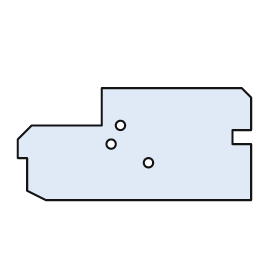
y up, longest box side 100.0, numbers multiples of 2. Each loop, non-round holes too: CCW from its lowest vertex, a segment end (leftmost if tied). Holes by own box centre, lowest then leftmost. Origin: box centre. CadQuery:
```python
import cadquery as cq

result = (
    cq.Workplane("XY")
    .moveTo(-38.0, -24.0)
    .lineTo(50.0, -24.0)
    .lineTo(50.0, 0.0)
    .lineTo(42.0, 0.0)
    .lineTo(42.0, 6.0)
    .lineTo(50.0, 6.0)
    .lineTo(50.0, 20.0)
    .lineTo(46.0, 24.0)
    .lineTo(-14.0, 24.0)
    .lineTo(-14.0, 8.0)
    .lineTo(-44.0, 8.0)
    .lineTo(-50.0, 2.0)
    .lineTo(-50.0, -6.0)
    .lineTo(-46.0, -6.0)
    .lineTo(-46.0, -20.0)
    .close()
    .moveTo(6.0, -8.0)
    .circle(2.0)
    .moveTo(-10.0, 0.0)
    .circle(2.0)
    .moveTo(-6.0, 8.0)
    .circle(2.0)
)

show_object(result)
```